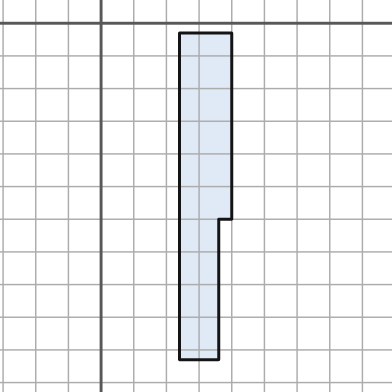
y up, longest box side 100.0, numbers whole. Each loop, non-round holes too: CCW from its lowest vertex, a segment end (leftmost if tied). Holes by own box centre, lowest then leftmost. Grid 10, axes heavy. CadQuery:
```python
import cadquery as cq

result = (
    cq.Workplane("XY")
    .moveTo(24.0, -103.0)
    .lineTo(36.0, -103.0)
    .lineTo(36.0, -60.0)
    .lineTo(40.0, -60.0)
    .lineTo(40.0, -3.0)
    .lineTo(24.0, -3.0)
    .close()
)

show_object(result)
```